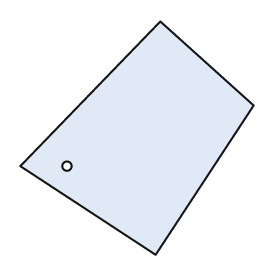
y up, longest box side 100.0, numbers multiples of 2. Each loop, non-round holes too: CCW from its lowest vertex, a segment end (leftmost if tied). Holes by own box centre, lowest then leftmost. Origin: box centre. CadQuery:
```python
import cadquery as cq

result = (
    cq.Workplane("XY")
    .moveTo(8.0, -50.0)
    .lineTo(50.0, 14.0)
    .lineTo(10.0, 50.0)
    .lineTo(-50.0, -12.0)
    .close()
    .moveTo(-30.0, -12.0)
    .circle(2.0)
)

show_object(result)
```